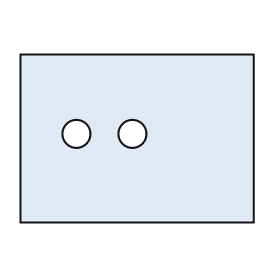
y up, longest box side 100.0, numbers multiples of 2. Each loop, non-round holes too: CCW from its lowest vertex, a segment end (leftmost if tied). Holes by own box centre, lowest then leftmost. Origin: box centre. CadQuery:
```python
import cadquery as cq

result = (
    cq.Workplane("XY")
    .moveTo(-50.0, -36.0)
    .lineTo(50.0, -36.0)
    .lineTo(50.0, 36.0)
    .lineTo(-50.0, 36.0)
    .close()
    .moveTo(-26.0, 2.0)
    .circle(6.0)
    .moveTo(-2.0, 2.0)
    .circle(6.0)
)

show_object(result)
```